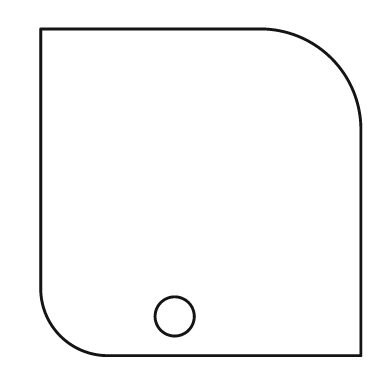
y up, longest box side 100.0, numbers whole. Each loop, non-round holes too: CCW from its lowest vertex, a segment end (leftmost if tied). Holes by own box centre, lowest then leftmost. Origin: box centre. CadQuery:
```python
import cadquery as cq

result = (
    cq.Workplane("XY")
    .moveTo(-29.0, -50.0)
    .lineTo(49.0, -50.0)
    .lineTo(49.0, 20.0)
    .threePointArc((40.0, 41.0), (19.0, 50.0))
    .lineTo(-49.0, 50.0)
    .lineTo(-49.0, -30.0)
    .threePointArc((-43.0, -44.0), (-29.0, -50.0))
    .close()
    .moveTo(-8.0, -38.0)
    .circle(6.0)
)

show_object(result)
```